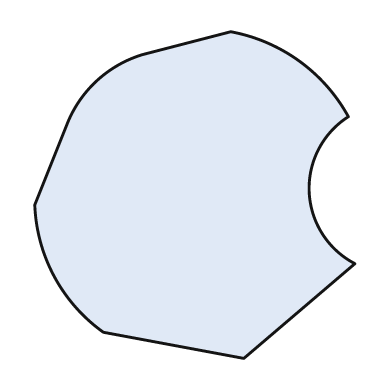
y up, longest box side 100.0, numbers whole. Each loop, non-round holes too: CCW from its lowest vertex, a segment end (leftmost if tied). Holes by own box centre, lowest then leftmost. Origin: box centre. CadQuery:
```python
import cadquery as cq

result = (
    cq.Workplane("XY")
    .moveTo(15.0, -50.0)
    .lineTo(49.0, -21.0)
    .threePointArc((35.0, 1.0), (47.0, 24.0))
    .threePointArc((32.0, 41.0), (11.0, 50.0))
    .lineTo(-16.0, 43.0)
    .threePointArc((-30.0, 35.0), (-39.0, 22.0))
    .lineTo(-49.0, -3.0)
    .threePointArc((-43.0, -25.0), (-28.0, -42.0))
    .close()
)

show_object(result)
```